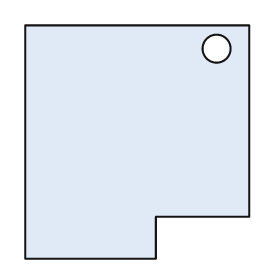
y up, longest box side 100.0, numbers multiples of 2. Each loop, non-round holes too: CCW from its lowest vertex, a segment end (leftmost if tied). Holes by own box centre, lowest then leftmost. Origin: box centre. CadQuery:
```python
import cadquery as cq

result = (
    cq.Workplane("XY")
    .moveTo(-48.0, -50.0)
    .lineTo(8.0, -50.0)
    .lineTo(8.0, -32.0)
    .lineTo(48.0, -32.0)
    .lineTo(48.0, 50.0)
    .lineTo(-48.0, 50.0)
    .close()
    .moveTo(34.0, 40.0)
    .circle(6.0)
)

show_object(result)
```